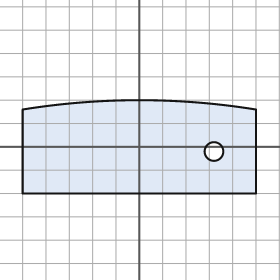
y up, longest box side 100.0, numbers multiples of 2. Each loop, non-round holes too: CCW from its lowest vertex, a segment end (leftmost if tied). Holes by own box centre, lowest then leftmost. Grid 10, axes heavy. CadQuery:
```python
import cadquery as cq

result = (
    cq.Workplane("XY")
    .moveTo(-50.0, -20.0)
    .lineTo(50.0, -20.0)
    .lineTo(50.0, 16.0)
    .threePointArc((0.0, 20.0), (-50.0, 16.0))
    .close()
    .moveTo(32.0, -2.0)
    .circle(4.0)
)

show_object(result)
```